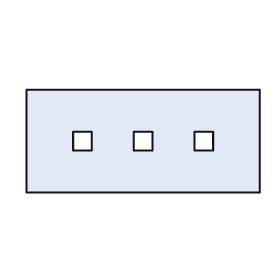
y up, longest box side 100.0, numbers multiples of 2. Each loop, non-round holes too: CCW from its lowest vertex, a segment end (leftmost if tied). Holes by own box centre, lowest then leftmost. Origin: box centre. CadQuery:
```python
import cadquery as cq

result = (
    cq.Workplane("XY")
    .moveTo(-50.0, -22.0)
    .lineTo(50.0, -22.0)
    .lineTo(50.0, 22.0)
    .lineTo(-50.0, 22.0)
    .close()
    .moveTo(-30.0, -4.0)
    .lineTo(-22.0, -4.0)
    .lineTo(-22.0, 4.0)
    .lineTo(-30.0, 4.0)
    .close()
    .moveTo(-4.0, -4.0)
    .lineTo(4.0, -4.0)
    .lineTo(4.0, 4.0)
    .lineTo(-4.0, 4.0)
    .close()
    .moveTo(22.0, -4.0)
    .lineTo(30.0, -4.0)
    .lineTo(30.0, 4.0)
    .lineTo(22.0, 4.0)
    .close()
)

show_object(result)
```